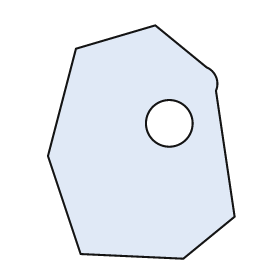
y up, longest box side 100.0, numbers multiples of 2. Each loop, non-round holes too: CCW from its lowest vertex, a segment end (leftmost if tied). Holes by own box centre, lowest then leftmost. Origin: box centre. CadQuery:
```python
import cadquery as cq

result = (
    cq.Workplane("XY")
    .moveTo(18.0, -50.0)
    .lineTo(40.0, -32.0)
    .lineTo(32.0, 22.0)
    .threePointArc((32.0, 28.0), (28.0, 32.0))
    .lineTo(6.0, 50.0)
    .lineTo(-28.0, 40.0)
    .lineTo(-40.0, -6.0)
    .lineTo(-26.0, -48.0)
    .close()
    .moveTo(12.0, 8.0)
    .circle(10.0)
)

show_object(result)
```